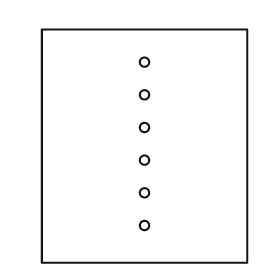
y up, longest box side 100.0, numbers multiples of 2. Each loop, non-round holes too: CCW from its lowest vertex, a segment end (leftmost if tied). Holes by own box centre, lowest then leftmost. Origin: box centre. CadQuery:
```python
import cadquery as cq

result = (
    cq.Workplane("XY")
    .moveTo(-44.0, -50.0)
    .lineTo(44.0, -50.0)
    .lineTo(44.0, 50.0)
    .lineTo(-44.0, 50.0)
    .close()
    .moveTo(0.0, -34.0)
    .circle(2.0)
    .moveTo(0.0, -20.0)
    .circle(2.0)
    .moveTo(0.0, -6.0)
    .circle(2.0)
    .moveTo(0.0, 8.0)
    .circle(2.0)
    .moveTo(0.0, 22.0)
    .circle(2.0)
    .moveTo(0.0, 36.0)
    .circle(2.0)
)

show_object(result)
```